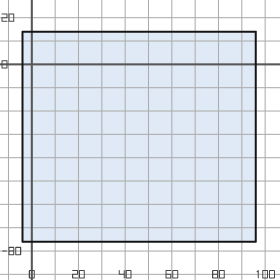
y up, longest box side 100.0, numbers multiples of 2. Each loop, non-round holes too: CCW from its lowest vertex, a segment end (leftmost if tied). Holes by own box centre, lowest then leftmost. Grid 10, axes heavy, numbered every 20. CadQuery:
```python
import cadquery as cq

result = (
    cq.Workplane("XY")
    .moveTo(-4.0, -76.0)
    .lineTo(96.0, -76.0)
    .lineTo(96.0, 14.0)
    .lineTo(-4.0, 14.0)
    .close()
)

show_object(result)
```